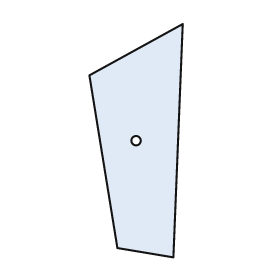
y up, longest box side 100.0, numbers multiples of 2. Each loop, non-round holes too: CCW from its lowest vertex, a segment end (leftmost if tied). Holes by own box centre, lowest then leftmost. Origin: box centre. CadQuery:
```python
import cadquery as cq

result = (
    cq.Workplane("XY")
    .moveTo(16.0, -50.0)
    .lineTo(20.0, 50.0)
    .lineTo(-20.0, 28.0)
    .lineTo(-8.0, -46.0)
    .close()
    .moveTo(0.0, 0.0)
    .circle(2.0)
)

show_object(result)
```